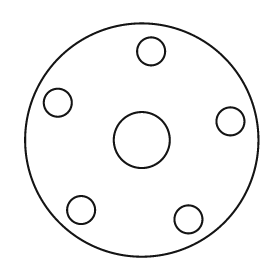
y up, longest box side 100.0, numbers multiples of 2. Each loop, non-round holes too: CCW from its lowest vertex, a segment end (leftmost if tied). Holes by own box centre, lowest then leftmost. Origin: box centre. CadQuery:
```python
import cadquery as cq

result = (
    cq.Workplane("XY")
    .moveTo(0.0, 0.0)
    .circle(50.0)
    .moveTo(20.0, -34.0)
    .circle(6.0)
    .moveTo(-26.0, -30.0)
    .circle(6.0)
    .moveTo(0.0, 0.0)
    .circle(12.0)
    .moveTo(38.0, 8.0)
    .circle(6.0)
    .moveTo(-36.0, 16.0)
    .circle(6.0)
    .moveTo(4.0, 38.0)
    .circle(6.0)
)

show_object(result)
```